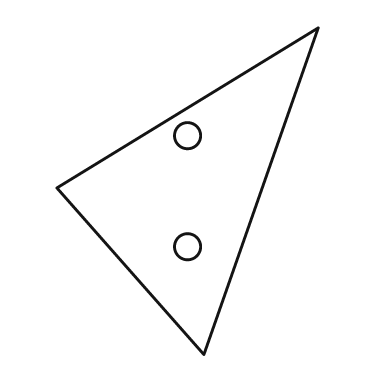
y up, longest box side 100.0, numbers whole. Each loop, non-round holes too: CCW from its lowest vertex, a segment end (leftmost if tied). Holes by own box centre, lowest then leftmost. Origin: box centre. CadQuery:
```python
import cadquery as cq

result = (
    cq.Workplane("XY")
    .moveTo(5.0, -50.0)
    .lineTo(40.0, 50.0)
    .lineTo(-40.0, 1.0)
    .close()
    .moveTo(0.0, -17.0)
    .circle(4.0)
    .moveTo(0.0, 17.0)
    .circle(4.0)
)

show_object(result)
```